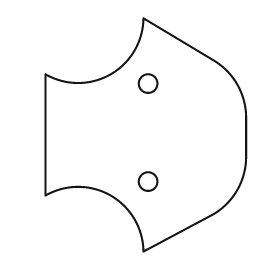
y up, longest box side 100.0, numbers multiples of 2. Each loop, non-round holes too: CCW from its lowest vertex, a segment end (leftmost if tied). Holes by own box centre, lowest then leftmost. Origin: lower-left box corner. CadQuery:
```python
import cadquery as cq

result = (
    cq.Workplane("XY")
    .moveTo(42.0, 0.0)
    .lineTo(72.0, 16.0)
    .threePointArc((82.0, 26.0), (86.0, 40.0))
    .lineTo(86.0, 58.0)
    .threePointArc((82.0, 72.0), (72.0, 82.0))
    .lineTo(42.0, 100.0)
    .threePointArc((28.0, 76.0), (0.0, 76.0))
    .lineTo(0.0, 24.0)
    .threePointArc((28.0, 24.0), (42.0, 0.0))
    .close()
    .moveTo(44.0, 30.0)
    .circle(4.0)
    .moveTo(44.0, 72.0)
    .circle(4.0)
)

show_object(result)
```